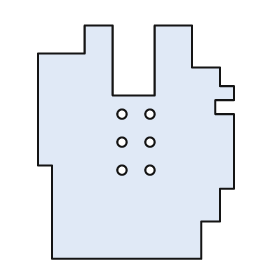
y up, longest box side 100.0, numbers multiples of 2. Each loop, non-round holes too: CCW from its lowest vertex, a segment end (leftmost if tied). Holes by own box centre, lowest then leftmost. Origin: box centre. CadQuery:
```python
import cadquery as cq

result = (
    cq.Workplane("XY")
    .moveTo(-36.0, -50.0)
    .lineTo(28.0, -50.0)
    .lineTo(28.0, -34.0)
    .lineTo(36.0, -34.0)
    .lineTo(36.0, -20.0)
    .lineTo(42.0, -20.0)
    .lineTo(42.0, 12.0)
    .lineTo(34.0, 12.0)
    .lineTo(34.0, 18.0)
    .lineTo(42.0, 18.0)
    .lineTo(42.0, 24.0)
    .lineTo(36.0, 24.0)
    .lineTo(36.0, 32.0)
    .lineTo(24.0, 32.0)
    .lineTo(24.0, 50.0)
    .lineTo(8.0, 50.0)
    .lineTo(8.0, 20.0)
    .lineTo(-10.0, 20.0)
    .lineTo(-10.0, 50.0)
    .lineTo(-22.0, 50.0)
    .lineTo(-22.0, 38.0)
    .lineTo(-42.0, 38.0)
    .lineTo(-42.0, -10.0)
    .lineTo(-36.0, -10.0)
    .close()
    .moveTo(-6.0, -12.0)
    .circle(2.0)
    .moveTo(6.0, -12.0)
    .circle(2.0)
    .moveTo(-6.0, 0.0)
    .circle(2.0)
    .moveTo(6.0, 0.0)
    .circle(2.0)
    .moveTo(-6.0, 12.0)
    .circle(2.0)
    .moveTo(6.0, 12.0)
    .circle(2.0)
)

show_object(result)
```